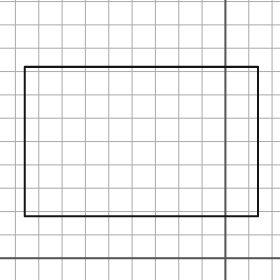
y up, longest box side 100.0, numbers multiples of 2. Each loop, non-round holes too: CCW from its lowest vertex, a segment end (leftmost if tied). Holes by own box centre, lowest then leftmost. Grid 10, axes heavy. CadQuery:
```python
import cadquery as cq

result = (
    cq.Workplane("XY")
    .moveTo(-86.0, 18.0)
    .lineTo(14.0, 18.0)
    .lineTo(14.0, 82.0)
    .lineTo(-86.0, 82.0)
    .close()
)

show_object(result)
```